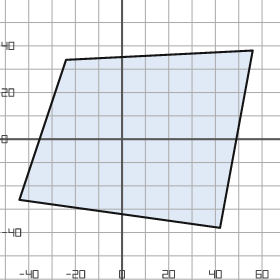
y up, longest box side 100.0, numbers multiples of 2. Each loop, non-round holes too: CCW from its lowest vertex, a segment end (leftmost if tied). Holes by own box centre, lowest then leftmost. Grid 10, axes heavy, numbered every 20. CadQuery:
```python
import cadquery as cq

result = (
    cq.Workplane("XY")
    .moveTo(42.0, -38.0)
    .lineTo(56.0, 38.0)
    .lineTo(-24.0, 34.0)
    .lineTo(-44.0, -26.0)
    .close()
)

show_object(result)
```